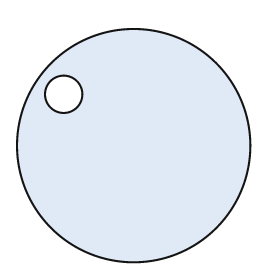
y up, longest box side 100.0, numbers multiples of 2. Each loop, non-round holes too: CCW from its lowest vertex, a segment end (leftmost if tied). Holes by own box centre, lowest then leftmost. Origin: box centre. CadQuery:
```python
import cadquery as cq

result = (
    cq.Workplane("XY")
    .moveTo(0.0, 0.0)
    .circle(50.0)
    .moveTo(-30.0, 22.0)
    .circle(8.0)
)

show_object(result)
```